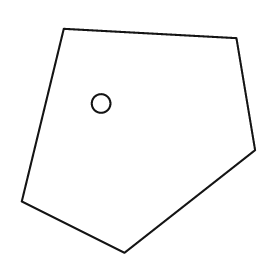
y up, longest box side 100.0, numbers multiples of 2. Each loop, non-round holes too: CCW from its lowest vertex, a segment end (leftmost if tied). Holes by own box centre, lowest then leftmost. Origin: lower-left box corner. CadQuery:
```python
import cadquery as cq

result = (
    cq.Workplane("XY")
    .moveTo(44.0, 0.0)
    .lineTo(100.0, 44.0)
    .lineTo(92.0, 92.0)
    .lineTo(18.0, 96.0)
    .lineTo(0.0, 22.0)
    .close()
    .moveTo(34.0, 64.0)
    .circle(4.0)
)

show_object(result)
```